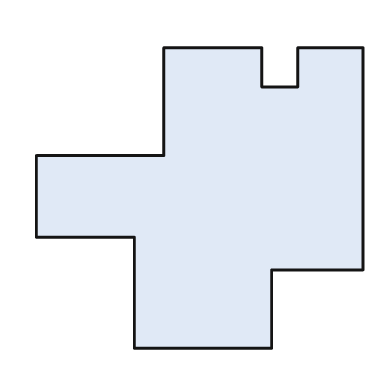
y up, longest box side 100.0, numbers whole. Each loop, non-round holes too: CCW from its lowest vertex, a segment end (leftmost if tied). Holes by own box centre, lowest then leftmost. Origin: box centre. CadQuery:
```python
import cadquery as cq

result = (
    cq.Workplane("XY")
    .moveTo(-20.0, -46.0)
    .lineTo(22.0, -46.0)
    .lineTo(22.0, -22.0)
    .lineTo(50.0, -22.0)
    .lineTo(50.0, 46.0)
    .lineTo(30.0, 46.0)
    .lineTo(30.0, 34.0)
    .lineTo(19.0, 34.0)
    .lineTo(19.0, 46.0)
    .lineTo(-11.0, 46.0)
    .lineTo(-11.0, 13.0)
    .lineTo(-50.0, 13.0)
    .lineTo(-50.0, -12.0)
    .lineTo(-20.0, -12.0)
    .close()
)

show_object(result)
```